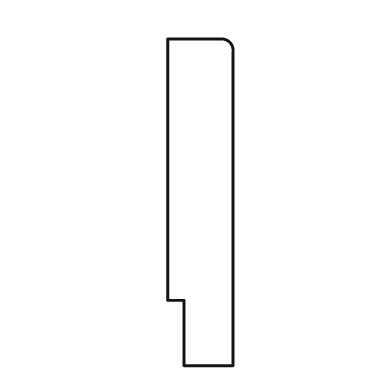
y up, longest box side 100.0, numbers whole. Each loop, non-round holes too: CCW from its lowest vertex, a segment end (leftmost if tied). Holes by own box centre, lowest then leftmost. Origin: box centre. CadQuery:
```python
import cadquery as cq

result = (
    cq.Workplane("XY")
    .moveTo(-5.0, -50.0)
    .lineTo(10.0, -50.0)
    .lineTo(10.0, 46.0)
    .threePointArc((9.0, 49.0), (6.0, 50.0))
    .lineTo(-10.0, 50.0)
    .lineTo(-10.0, -30.0)
    .lineTo(-5.0, -30.0)
    .close()
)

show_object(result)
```